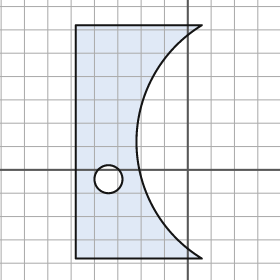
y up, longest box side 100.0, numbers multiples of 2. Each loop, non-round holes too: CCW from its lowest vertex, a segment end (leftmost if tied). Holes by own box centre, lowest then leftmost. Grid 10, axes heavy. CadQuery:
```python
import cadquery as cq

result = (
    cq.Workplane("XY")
    .moveTo(-48.0, -38.0)
    .lineTo(6.0, -38.0)
    .threePointArc((-22.0, 12.0), (6.0, 62.0))
    .lineTo(-48.0, 62.0)
    .close()
    .moveTo(-34.0, -4.0)
    .circle(6.0)
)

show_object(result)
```